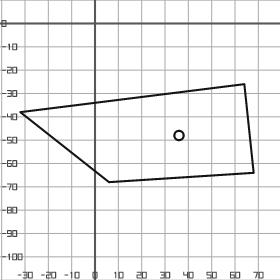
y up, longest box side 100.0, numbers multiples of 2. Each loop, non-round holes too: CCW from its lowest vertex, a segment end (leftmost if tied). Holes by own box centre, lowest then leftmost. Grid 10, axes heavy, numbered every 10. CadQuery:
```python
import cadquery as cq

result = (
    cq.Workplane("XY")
    .moveTo(6.0, -68.0)
    .lineTo(68.0, -64.0)
    .lineTo(64.0, -26.0)
    .lineTo(-32.0, -38.0)
    .close()
    .moveTo(36.0, -48.0)
    .circle(2.0)
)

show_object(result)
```